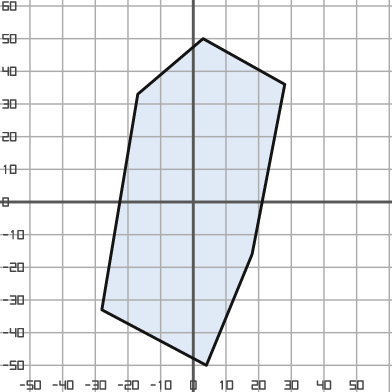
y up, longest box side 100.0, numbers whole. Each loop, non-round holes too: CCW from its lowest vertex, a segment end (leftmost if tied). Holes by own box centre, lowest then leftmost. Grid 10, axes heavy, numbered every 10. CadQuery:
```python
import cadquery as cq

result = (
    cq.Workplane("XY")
    .moveTo(4.0, -50.0)
    .lineTo(18.0, -16.0)
    .lineTo(28.0, 36.0)
    .lineTo(3.0, 50.0)
    .lineTo(-17.0, 33.0)
    .lineTo(-28.0, -33.0)
    .close()
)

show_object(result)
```